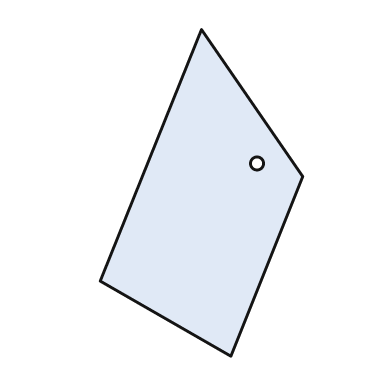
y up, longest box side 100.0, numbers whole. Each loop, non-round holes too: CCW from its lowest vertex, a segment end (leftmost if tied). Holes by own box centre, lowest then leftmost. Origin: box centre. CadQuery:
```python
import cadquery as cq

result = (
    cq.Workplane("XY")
    .moveTo(9.0, -50.0)
    .lineTo(31.0, 5.0)
    .lineTo(0.0, 50.0)
    .lineTo(-31.0, -27.0)
    .close()
    .moveTo(17.0, 9.0)
    .circle(2.0)
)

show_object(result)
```